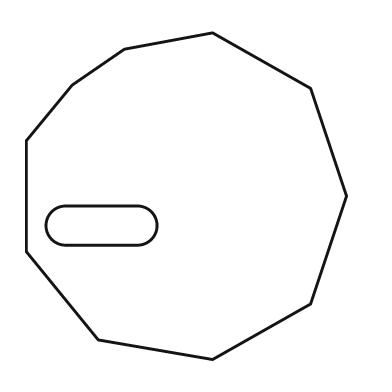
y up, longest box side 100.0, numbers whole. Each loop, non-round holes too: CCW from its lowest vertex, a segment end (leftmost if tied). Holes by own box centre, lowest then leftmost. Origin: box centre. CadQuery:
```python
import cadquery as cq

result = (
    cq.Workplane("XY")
    .moveTo(8.0, -50.0)
    .lineTo(38.0, -33.0)
    .lineTo(49.0, 0.0)
    .lineTo(38.0, 33.0)
    .lineTo(8.0, 50.0)
    .lineTo(-19.0, 45.0)
    .lineTo(-35.0, 34.0)
    .lineTo(-49.0, 17.0)
    .lineTo(-49.0, -17.0)
    .lineTo(-27.0, -44.0)
    .close()
    .moveTo(-37.0, -15.0)
    .lineTo(-15.0, -15.0)
    .threePointArc((-9.0, -9.0), (-15.0, -3.0))
    .lineTo(-37.0, -3.0)
    .threePointArc((-43.0, -9.0), (-37.0, -15.0))
    .close()
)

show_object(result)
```